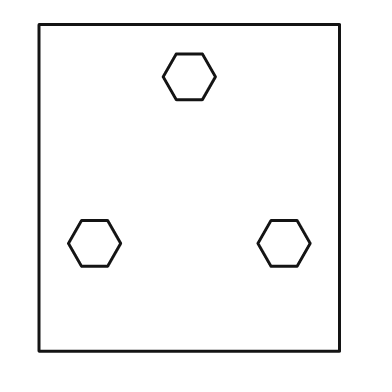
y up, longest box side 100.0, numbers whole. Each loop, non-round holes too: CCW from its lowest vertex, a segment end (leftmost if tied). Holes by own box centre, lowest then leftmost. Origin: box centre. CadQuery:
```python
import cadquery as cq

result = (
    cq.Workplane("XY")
    .moveTo(-46.0, -50.0)
    .lineTo(46.0, -50.0)
    .lineTo(46.0, 50.0)
    .lineTo(-46.0, 50.0)
    .close()
    .moveTo(-33.0, -24.0)
    .lineTo(-25.0, -24.0)
    .lineTo(-21.0, -17.0)
    .lineTo(-25.0, -10.0)
    .lineTo(-33.0, -10.0)
    .lineTo(-37.0, -17.0)
    .close()
    .moveTo(25.0, -24.0)
    .lineTo(33.0, -24.0)
    .lineTo(37.0, -17.0)
    .lineTo(33.0, -10.0)
    .lineTo(25.0, -10.0)
    .lineTo(21.0, -17.0)
    .close()
    .moveTo(-4.0, 27.0)
    .lineTo(4.0, 27.0)
    .lineTo(8.0, 34.0)
    .lineTo(4.0, 41.0)
    .lineTo(-4.0, 41.0)
    .lineTo(-8.0, 34.0)
    .close()
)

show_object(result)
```